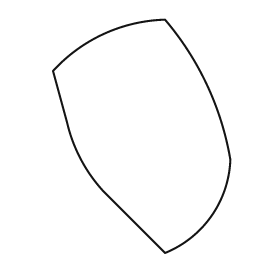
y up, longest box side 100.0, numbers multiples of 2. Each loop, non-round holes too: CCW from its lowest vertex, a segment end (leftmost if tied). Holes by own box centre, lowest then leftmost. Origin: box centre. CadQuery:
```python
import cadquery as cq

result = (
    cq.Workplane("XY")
    .moveTo(10.0, -50.0)
    .threePointArc((30.0, -34.0), (38.0, -10.0))
    .threePointArc((28.0, 22.0), (10.0, 50.0))
    .threePointArc((-16.0, 44.0), (-38.0, 28.0))
    .lineTo(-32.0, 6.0)
    .threePointArc((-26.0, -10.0), (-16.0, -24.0))
    .close()
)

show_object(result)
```